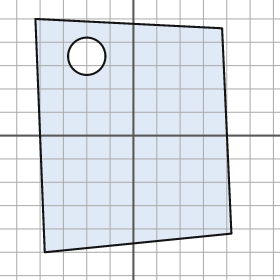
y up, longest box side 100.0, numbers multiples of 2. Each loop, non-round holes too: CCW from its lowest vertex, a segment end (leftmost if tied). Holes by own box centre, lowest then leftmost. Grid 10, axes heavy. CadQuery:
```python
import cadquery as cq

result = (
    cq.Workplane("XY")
    .moveTo(-38.0, -50.0)
    .lineTo(42.0, -42.0)
    .lineTo(38.0, 46.0)
    .lineTo(-42.0, 50.0)
    .close()
    .moveTo(-20.0, 34.0)
    .circle(8.0)
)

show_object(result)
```